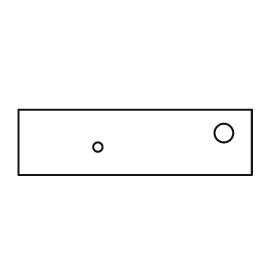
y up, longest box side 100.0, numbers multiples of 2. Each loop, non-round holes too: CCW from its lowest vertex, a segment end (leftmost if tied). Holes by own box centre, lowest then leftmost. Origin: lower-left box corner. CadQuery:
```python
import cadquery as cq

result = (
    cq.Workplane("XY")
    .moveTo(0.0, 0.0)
    .lineTo(100.0, 0.0)
    .lineTo(100.0, 28.0)
    .lineTo(0.0, 28.0)
    .close()
    .moveTo(34.0, 12.0)
    .circle(2.0)
    .moveTo(88.0, 18.0)
    .circle(4.0)
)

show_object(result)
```